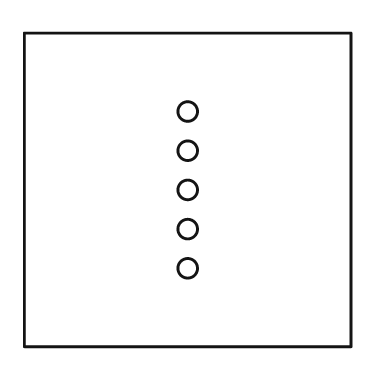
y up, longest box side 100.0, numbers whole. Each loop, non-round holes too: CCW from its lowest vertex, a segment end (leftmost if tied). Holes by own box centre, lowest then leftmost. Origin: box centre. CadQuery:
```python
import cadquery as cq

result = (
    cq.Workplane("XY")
    .moveTo(-50.0, -48.0)
    .lineTo(50.0, -48.0)
    .lineTo(50.0, 48.0)
    .lineTo(-50.0, 48.0)
    .close()
    .moveTo(0.0, -24.0)
    .circle(3.0)
    .moveTo(0.0, -12.0)
    .circle(3.0)
    .moveTo(0.0, 0.0)
    .circle(3.0)
    .moveTo(0.0, 12.0)
    .circle(3.0)
    .moveTo(0.0, 24.0)
    .circle(3.0)
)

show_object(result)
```